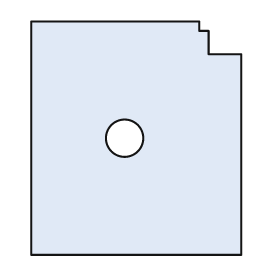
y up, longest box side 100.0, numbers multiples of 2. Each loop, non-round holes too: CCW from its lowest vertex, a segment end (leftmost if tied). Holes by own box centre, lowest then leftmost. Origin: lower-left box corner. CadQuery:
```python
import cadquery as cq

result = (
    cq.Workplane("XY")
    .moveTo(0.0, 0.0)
    .lineTo(90.0, 0.0)
    .lineTo(90.0, 86.0)
    .lineTo(76.0, 86.0)
    .lineTo(76.0, 96.0)
    .lineTo(72.0, 96.0)
    .lineTo(72.0, 100.0)
    .lineTo(0.0, 100.0)
    .close()
    .moveTo(40.0, 50.0)
    .circle(8.0)
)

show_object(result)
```